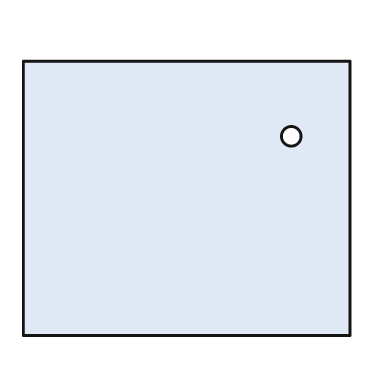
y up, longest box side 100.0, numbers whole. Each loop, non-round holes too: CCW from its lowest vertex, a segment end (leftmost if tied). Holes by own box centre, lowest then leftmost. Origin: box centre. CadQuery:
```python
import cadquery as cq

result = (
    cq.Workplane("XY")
    .moveTo(-50.0, -42.0)
    .lineTo(50.0, -42.0)
    .lineTo(50.0, 42.0)
    .lineTo(-50.0, 42.0)
    .close()
    .moveTo(32.0, 19.0)
    .circle(3.0)
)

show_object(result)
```